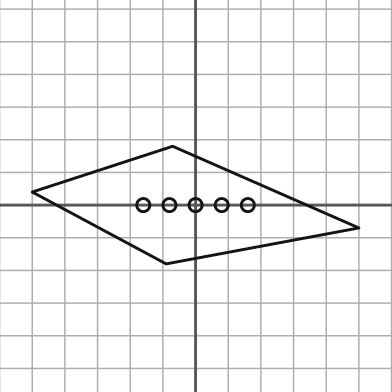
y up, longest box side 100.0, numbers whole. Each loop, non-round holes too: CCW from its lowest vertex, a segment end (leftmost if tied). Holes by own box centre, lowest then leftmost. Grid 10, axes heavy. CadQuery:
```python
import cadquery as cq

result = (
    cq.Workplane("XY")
    .moveTo(-9.0, -18.0)
    .lineTo(50.0, -7.0)
    .lineTo(-7.0, 18.0)
    .lineTo(-50.0, 4.0)
    .close()
    .moveTo(-16.0, 0.0)
    .circle(2.0)
    .moveTo(-8.0, 0.0)
    .circle(2.0)
    .moveTo(0.0, 0.0)
    .circle(2.0)
    .moveTo(8.0, 0.0)
    .circle(2.0)
    .moveTo(16.0, 0.0)
    .circle(2.0)
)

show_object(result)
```